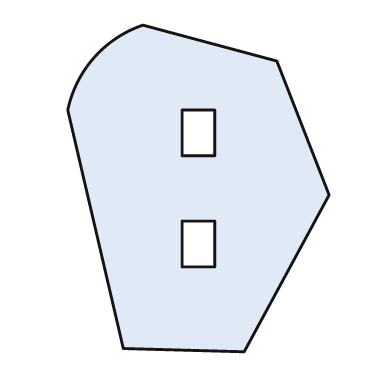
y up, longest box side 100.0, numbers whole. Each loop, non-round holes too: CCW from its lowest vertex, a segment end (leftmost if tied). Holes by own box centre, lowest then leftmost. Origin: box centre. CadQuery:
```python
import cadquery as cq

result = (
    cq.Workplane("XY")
    .moveTo(14.0, -50.0)
    .lineTo(40.0, -2.0)
    .lineTo(24.0, 39.0)
    .lineTo(-17.0, 50.0)
    .threePointArc((-32.0, 40.0), (-40.0, 24.0))
    .lineTo(-23.0, -49.0)
    .close()
    .moveTo(-5.0, -24.0)
    .lineTo(5.0, -24.0)
    .lineTo(5.0, -10.0)
    .lineTo(-5.0, -10.0)
    .close()
    .moveTo(-5.0, 10.0)
    .lineTo(5.0, 10.0)
    .lineTo(5.0, 24.0)
    .lineTo(-5.0, 24.0)
    .close()
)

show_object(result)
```